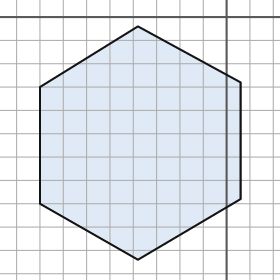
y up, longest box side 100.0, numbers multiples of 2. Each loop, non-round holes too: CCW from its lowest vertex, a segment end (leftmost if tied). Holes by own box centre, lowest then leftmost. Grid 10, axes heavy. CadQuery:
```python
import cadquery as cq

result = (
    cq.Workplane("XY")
    .moveTo(-38.0, -104.0)
    .lineTo(6.0, -78.0)
    .lineTo(6.0, -28.0)
    .lineTo(-38.0, -4.0)
    .lineTo(-80.0, -30.0)
    .lineTo(-80.0, -80.0)
    .close()
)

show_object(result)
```